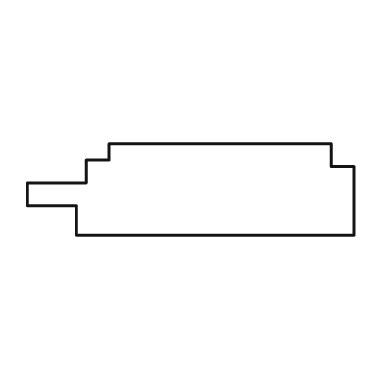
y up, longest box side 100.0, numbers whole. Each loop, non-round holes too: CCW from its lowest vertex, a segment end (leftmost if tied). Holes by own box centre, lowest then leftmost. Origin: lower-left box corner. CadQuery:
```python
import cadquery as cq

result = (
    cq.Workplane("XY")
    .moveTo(15.0, 0.0)
    .lineTo(100.0, 0.0)
    .lineTo(100.0, 21.0)
    .lineTo(93.0, 21.0)
    .lineTo(93.0, 28.0)
    .lineTo(25.0, 28.0)
    .lineTo(25.0, 23.0)
    .lineTo(18.0, 23.0)
    .lineTo(18.0, 16.0)
    .lineTo(0.0, 16.0)
    .lineTo(0.0, 9.0)
    .lineTo(15.0, 9.0)
    .close()
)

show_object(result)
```